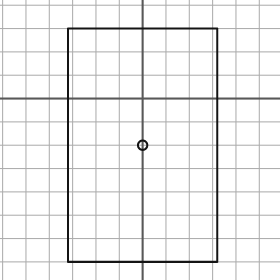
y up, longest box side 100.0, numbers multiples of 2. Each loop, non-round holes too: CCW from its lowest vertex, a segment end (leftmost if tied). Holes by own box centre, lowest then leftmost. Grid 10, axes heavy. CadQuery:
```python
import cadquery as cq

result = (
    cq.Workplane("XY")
    .moveTo(-32.0, -70.0)
    .lineTo(32.0, -70.0)
    .lineTo(32.0, 30.0)
    .lineTo(-32.0, 30.0)
    .close()
    .moveTo(0.0, -20.0)
    .circle(2.0)
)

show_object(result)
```